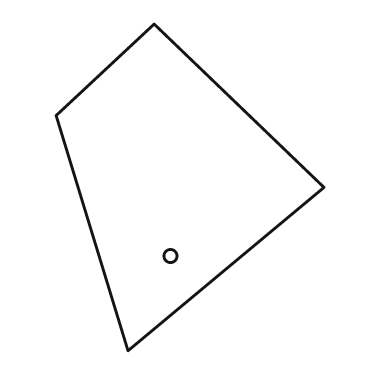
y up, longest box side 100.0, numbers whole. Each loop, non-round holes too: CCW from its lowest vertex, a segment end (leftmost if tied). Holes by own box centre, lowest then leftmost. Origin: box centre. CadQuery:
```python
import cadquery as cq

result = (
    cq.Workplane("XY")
    .moveTo(-19.0, -50.0)
    .lineTo(41.0, 0.0)
    .lineTo(-11.0, 50.0)
    .lineTo(-41.0, 22.0)
    .close()
    .moveTo(-6.0, -21.0)
    .circle(2.0)
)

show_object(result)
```